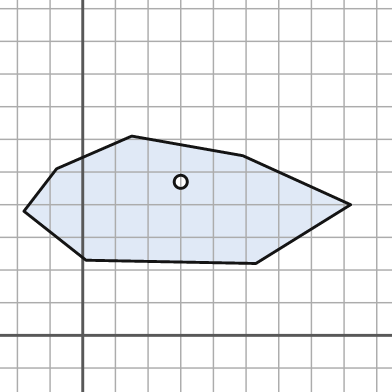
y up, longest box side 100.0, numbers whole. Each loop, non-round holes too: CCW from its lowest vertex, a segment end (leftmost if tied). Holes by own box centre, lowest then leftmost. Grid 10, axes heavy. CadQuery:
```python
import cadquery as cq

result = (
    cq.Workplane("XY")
    .moveTo(53.0, 22.0)
    .lineTo(82.0, 40.0)
    .lineTo(49.0, 55.0)
    .lineTo(15.0, 61.0)
    .lineTo(-8.0, 51.0)
    .lineTo(-18.0, 38.0)
    .lineTo(1.0, 23.0)
    .close()
    .moveTo(30.0, 47.0)
    .circle(2.0)
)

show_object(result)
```